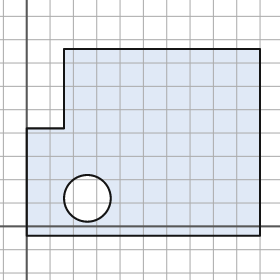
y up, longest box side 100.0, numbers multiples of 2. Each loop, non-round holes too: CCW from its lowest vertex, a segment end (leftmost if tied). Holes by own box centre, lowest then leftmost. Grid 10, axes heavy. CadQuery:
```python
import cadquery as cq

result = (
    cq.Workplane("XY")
    .moveTo(0.0, -4.0)
    .lineTo(100.0, -4.0)
    .lineTo(100.0, 76.0)
    .lineTo(16.0, 76.0)
    .lineTo(16.0, 42.0)
    .lineTo(0.0, 42.0)
    .close()
    .moveTo(26.0, 12.0)
    .circle(10.0)
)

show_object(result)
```